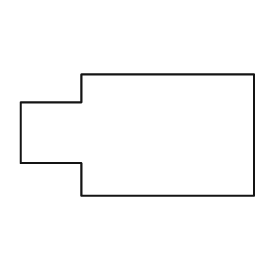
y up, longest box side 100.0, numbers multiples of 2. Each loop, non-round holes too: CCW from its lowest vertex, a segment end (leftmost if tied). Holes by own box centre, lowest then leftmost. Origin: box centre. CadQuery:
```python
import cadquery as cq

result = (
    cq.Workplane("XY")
    .moveTo(-24.0, -26.0)
    .lineTo(50.0, -26.0)
    .lineTo(50.0, 26.0)
    .lineTo(-24.0, 26.0)
    .lineTo(-24.0, 14.0)
    .lineTo(-50.0, 14.0)
    .lineTo(-50.0, -12.0)
    .lineTo(-24.0, -12.0)
    .close()
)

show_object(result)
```